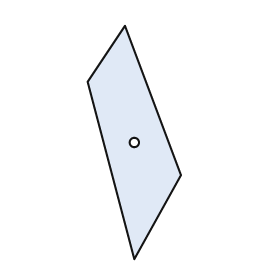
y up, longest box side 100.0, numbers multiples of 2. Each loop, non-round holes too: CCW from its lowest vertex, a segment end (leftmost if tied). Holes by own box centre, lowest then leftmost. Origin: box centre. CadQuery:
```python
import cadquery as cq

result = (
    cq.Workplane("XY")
    .moveTo(0.0, -50.0)
    .lineTo(20.0, -14.0)
    .lineTo(-4.0, 50.0)
    .lineTo(-20.0, 26.0)
    .close()
    .moveTo(0.0, 0.0)
    .circle(2.0)
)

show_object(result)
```